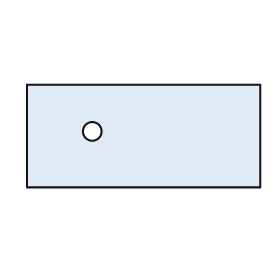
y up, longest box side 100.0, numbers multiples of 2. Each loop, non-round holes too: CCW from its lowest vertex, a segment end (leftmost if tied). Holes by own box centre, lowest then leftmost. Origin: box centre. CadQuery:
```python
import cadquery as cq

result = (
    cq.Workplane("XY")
    .moveTo(-50.0, -22.0)
    .lineTo(50.0, -22.0)
    .lineTo(50.0, 22.0)
    .lineTo(-50.0, 22.0)
    .close()
    .moveTo(-22.0, 2.0)
    .circle(4.0)
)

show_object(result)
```